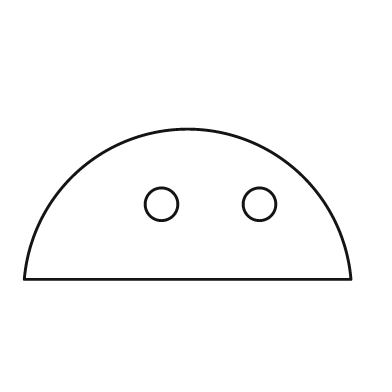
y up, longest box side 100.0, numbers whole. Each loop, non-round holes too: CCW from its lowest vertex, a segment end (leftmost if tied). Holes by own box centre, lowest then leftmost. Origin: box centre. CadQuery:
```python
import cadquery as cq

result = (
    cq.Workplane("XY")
    .moveTo(-50.0, -23.0)
    .lineTo(50.0, -23.0)
    .threePointArc((0.0, 23.0), (-50.0, -23.0))
    .close()
    .moveTo(-8.0, 0.0)
    .circle(5.0)
    .moveTo(22.0, 0.0)
    .circle(5.0)
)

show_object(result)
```